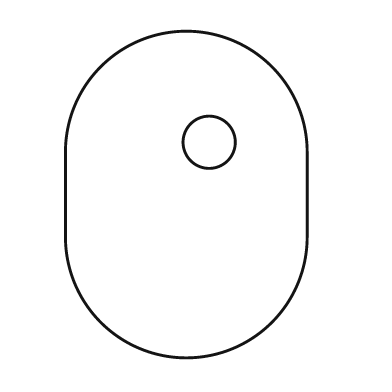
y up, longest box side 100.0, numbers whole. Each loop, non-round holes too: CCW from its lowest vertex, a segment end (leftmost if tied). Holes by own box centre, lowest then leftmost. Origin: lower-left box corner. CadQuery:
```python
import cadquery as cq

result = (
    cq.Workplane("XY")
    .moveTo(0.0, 37.0)
    .threePointArc((37.0, 0.0), (74.0, 37.0))
    .lineTo(74.0, 63.0)
    .threePointArc((37.0, 100.0), (0.0, 63.0))
    .close()
    .moveTo(44.0, 66.0)
    .circle(8.0)
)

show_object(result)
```